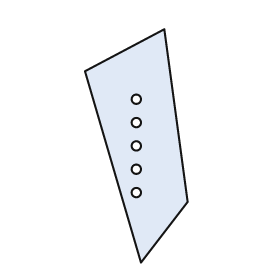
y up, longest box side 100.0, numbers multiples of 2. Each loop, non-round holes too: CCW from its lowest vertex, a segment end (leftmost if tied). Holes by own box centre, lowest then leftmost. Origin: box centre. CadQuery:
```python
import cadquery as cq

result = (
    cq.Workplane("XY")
    .moveTo(2.0, -50.0)
    .lineTo(22.0, -24.0)
    .lineTo(12.0, 50.0)
    .lineTo(-22.0, 32.0)
    .close()
    .moveTo(0.0, -20.0)
    .circle(2.0)
    .moveTo(0.0, -10.0)
    .circle(2.0)
    .moveTo(0.0, 0.0)
    .circle(2.0)
    .moveTo(0.0, 10.0)
    .circle(2.0)
    .moveTo(0.0, 20.0)
    .circle(2.0)
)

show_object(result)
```